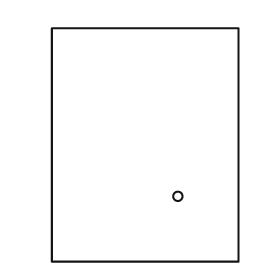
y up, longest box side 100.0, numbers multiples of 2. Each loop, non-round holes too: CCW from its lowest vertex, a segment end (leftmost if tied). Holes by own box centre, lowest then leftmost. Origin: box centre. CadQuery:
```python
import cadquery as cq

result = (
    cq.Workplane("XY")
    .moveTo(-40.0, -50.0)
    .lineTo(40.0, -50.0)
    .lineTo(40.0, 50.0)
    .lineTo(-40.0, 50.0)
    .close()
    .moveTo(14.0, -22.0)
    .circle(2.0)
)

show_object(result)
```